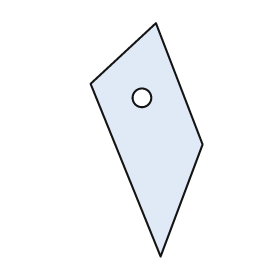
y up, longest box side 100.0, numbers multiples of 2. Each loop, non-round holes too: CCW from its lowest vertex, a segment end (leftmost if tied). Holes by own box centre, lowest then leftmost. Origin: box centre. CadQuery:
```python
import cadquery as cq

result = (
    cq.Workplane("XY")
    .moveTo(6.0, -50.0)
    .lineTo(24.0, -2.0)
    .lineTo(4.0, 50.0)
    .lineTo(-24.0, 24.0)
    .close()
    .moveTo(-2.0, 18.0)
    .circle(4.0)
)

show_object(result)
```